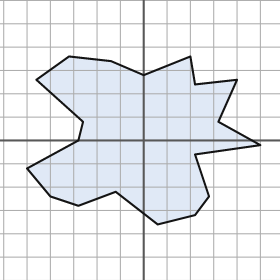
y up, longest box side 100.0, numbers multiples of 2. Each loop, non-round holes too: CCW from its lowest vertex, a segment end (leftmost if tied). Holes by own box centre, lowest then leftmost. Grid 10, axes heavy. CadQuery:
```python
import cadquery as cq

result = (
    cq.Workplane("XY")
    .moveTo(6.0, -36.0)
    .lineTo(22.0, -32.0)
    .lineTo(28.0, -24.0)
    .lineTo(22.0, -6.0)
    .lineTo(50.0, -2.0)
    .lineTo(32.0, 8.0)
    .lineTo(40.0, 26.0)
    .lineTo(22.0, 24.0)
    .lineTo(20.0, 36.0)
    .lineTo(0.0, 28.0)
    .lineTo(-14.0, 34.0)
    .lineTo(-32.0, 36.0)
    .lineTo(-46.0, 26.0)
    .lineTo(-26.0, 8.0)
    .lineTo(-28.0, 0.0)
    .lineTo(-50.0, -12.0)
    .lineTo(-40.0, -24.0)
    .lineTo(-28.0, -28.0)
    .lineTo(-12.0, -22.0)
    .close()
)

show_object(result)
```